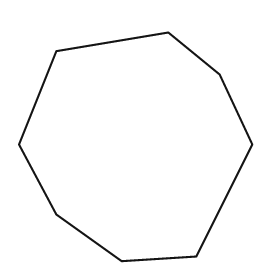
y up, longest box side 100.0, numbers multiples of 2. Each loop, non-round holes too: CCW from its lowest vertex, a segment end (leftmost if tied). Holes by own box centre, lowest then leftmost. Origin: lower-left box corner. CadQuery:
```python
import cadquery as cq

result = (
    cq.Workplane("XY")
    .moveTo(44.0, 0.0)
    .lineTo(76.0, 2.0)
    .lineTo(100.0, 50.0)
    .lineTo(86.0, 80.0)
    .lineTo(64.0, 98.0)
    .lineTo(16.0, 90.0)
    .lineTo(0.0, 50.0)
    .lineTo(16.0, 20.0)
    .close()
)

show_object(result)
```